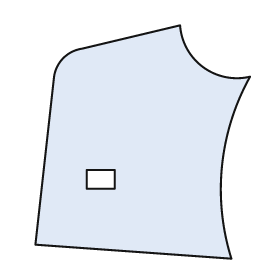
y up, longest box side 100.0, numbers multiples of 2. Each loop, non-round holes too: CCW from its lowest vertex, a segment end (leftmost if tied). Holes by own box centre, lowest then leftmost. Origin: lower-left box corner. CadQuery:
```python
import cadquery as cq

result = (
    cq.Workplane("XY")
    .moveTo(84.0, 0.0)
    .threePointArc((80.0, 40.0), (92.0, 78.0))
    .threePointArc((72.0, 82.0), (62.0, 100.0))
    .lineTo(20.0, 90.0)
    .threePointArc((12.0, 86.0), (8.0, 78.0))
    .lineTo(0.0, 6.0)
    .close()
    .moveTo(22.0, 30.0)
    .lineTo(34.0, 30.0)
    .lineTo(34.0, 38.0)
    .lineTo(22.0, 38.0)
    .close()
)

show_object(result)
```